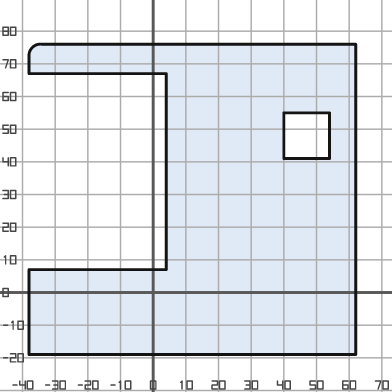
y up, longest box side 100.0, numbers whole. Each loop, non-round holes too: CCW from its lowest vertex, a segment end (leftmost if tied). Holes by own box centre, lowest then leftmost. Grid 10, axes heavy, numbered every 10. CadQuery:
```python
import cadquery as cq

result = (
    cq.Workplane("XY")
    .moveTo(-38.0, -19.0)
    .lineTo(62.0, -19.0)
    .lineTo(62.0, 76.0)
    .lineTo(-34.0, 76.0)
    .threePointArc((-37.0, 75.0), (-38.0, 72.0))
    .lineTo(-38.0, 67.0)
    .lineTo(4.0, 67.0)
    .lineTo(4.0, 7.0)
    .lineTo(-38.0, 7.0)
    .close()
    .moveTo(40.0, 41.0)
    .lineTo(54.0, 41.0)
    .lineTo(54.0, 55.0)
    .lineTo(40.0, 55.0)
    .close()
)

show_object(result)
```